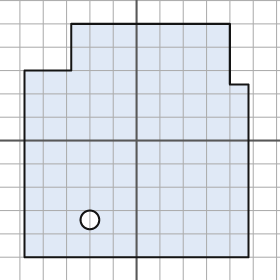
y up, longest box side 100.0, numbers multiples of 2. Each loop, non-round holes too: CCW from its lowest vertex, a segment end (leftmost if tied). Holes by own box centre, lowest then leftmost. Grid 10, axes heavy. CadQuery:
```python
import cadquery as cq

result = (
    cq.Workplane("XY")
    .moveTo(-48.0, -50.0)
    .lineTo(48.0, -50.0)
    .lineTo(48.0, 24.0)
    .lineTo(40.0, 24.0)
    .lineTo(40.0, 50.0)
    .lineTo(-28.0, 50.0)
    .lineTo(-28.0, 30.0)
    .lineTo(-48.0, 30.0)
    .close()
    .moveTo(-20.0, -34.0)
    .circle(4.0)
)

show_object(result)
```